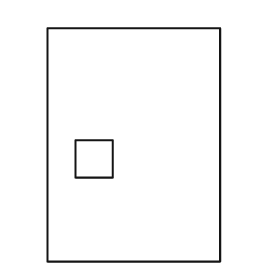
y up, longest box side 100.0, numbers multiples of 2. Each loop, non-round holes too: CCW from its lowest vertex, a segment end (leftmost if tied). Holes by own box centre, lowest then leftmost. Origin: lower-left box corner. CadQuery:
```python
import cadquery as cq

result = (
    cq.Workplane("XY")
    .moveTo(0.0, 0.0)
    .lineTo(74.0, 0.0)
    .lineTo(74.0, 100.0)
    .lineTo(0.0, 100.0)
    .close()
    .moveTo(12.0, 36.0)
    .lineTo(28.0, 36.0)
    .lineTo(28.0, 52.0)
    .lineTo(12.0, 52.0)
    .close()
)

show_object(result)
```